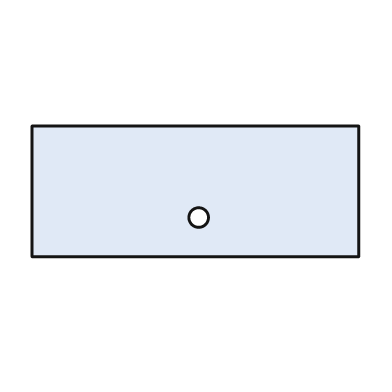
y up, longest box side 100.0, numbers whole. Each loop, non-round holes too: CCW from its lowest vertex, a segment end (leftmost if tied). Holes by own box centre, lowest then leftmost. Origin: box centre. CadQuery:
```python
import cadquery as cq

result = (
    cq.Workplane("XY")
    .moveTo(-50.0, -20.0)
    .lineTo(50.0, -20.0)
    .lineTo(50.0, 20.0)
    .lineTo(-50.0, 20.0)
    .close()
    .moveTo(1.0, -8.0)
    .circle(3.0)
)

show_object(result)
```